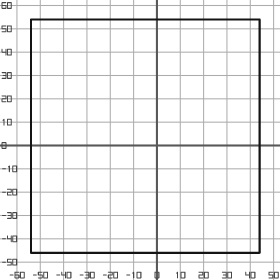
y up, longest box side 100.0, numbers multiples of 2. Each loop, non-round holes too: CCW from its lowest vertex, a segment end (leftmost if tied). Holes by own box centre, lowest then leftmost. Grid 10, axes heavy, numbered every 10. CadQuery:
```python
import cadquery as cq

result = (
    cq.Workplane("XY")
    .moveTo(-54.0, -46.0)
    .lineTo(44.0, -46.0)
    .lineTo(44.0, 54.0)
    .lineTo(-54.0, 54.0)
    .close()
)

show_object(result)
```